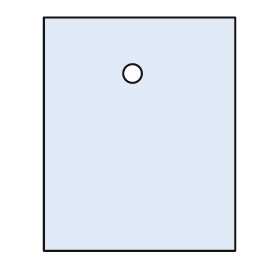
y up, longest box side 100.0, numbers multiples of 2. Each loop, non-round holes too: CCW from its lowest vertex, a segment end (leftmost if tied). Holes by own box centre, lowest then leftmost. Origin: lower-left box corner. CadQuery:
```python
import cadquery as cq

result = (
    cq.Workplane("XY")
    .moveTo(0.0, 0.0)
    .lineTo(82.0, 0.0)
    .lineTo(82.0, 100.0)
    .lineTo(0.0, 100.0)
    .close()
    .moveTo(38.0, 76.0)
    .circle(4.0)
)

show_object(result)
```